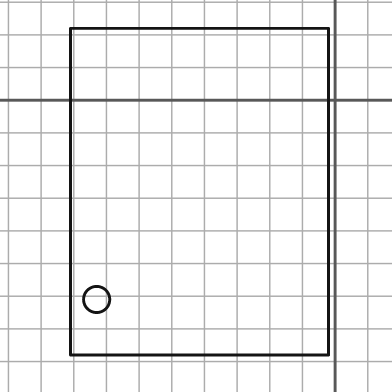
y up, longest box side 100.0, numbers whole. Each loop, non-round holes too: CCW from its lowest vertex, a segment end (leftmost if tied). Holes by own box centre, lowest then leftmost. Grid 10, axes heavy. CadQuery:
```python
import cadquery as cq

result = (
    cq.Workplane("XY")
    .moveTo(-81.0, -78.0)
    .lineTo(-2.0, -78.0)
    .lineTo(-2.0, 22.0)
    .lineTo(-81.0, 22.0)
    .close()
    .moveTo(-73.0, -61.0)
    .circle(4.0)
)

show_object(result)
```